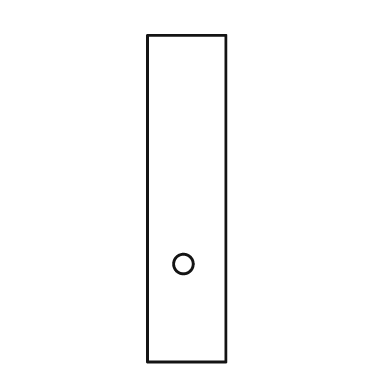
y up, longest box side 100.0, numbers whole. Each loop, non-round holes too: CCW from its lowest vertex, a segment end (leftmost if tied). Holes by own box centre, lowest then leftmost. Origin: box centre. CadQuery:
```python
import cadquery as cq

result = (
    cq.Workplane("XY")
    .moveTo(-12.0, -50.0)
    .lineTo(12.0, -50.0)
    .lineTo(12.0, 50.0)
    .lineTo(-12.0, 50.0)
    .close()
    .moveTo(-1.0, -20.0)
    .circle(3.0)
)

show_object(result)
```